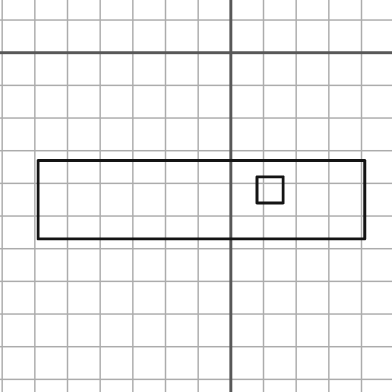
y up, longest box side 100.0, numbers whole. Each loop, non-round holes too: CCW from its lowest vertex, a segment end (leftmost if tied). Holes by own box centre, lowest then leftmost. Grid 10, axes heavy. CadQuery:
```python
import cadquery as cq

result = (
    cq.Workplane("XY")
    .moveTo(-59.0, -57.0)
    .lineTo(41.0, -57.0)
    .lineTo(41.0, -33.0)
    .lineTo(-59.0, -33.0)
    .close()
    .moveTo(8.0, -46.0)
    .lineTo(16.0, -46.0)
    .lineTo(16.0, -38.0)
    .lineTo(8.0, -38.0)
    .close()
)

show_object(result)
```